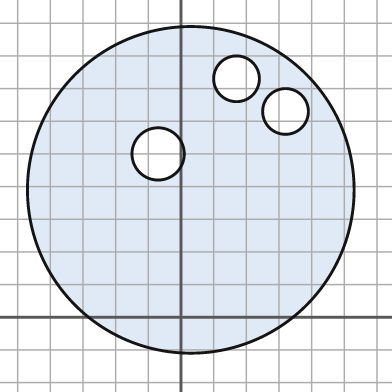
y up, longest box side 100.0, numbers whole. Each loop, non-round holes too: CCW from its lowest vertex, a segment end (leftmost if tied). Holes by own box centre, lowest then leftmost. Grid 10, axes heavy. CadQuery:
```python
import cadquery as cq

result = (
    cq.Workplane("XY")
    .moveTo(3.0, 39.0)
    .circle(50.0)
    .moveTo(-7.0, 50.0)
    .circle(8.0)
    .moveTo(32.0, 63.0)
    .circle(7.0)
    .moveTo(17.0, 73.0)
    .circle(7.0)
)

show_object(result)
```